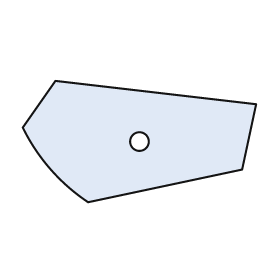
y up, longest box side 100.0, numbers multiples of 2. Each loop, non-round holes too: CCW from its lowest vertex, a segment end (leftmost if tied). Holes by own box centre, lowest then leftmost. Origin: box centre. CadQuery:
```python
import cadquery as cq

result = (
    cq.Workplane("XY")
    .moveTo(-22.0, -26.0)
    .lineTo(44.0, -12.0)
    .lineTo(50.0, 16.0)
    .lineTo(-36.0, 26.0)
    .lineTo(-50.0, 6.0)
    .threePointArc((-38.0, -12.0), (-22.0, -26.0))
    .close()
    .moveTo(0.0, 0.0)
    .circle(4.0)
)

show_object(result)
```